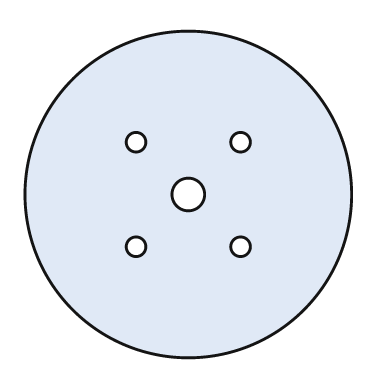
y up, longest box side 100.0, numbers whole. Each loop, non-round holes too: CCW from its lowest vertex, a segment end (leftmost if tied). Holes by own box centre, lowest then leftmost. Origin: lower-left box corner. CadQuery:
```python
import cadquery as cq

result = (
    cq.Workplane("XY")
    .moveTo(50.0, 50.0)
    .circle(50.0)
    .moveTo(34.0, 34.0)
    .circle(3.0)
    .moveTo(66.0, 34.0)
    .circle(3.0)
    .moveTo(50.0, 50.0)
    .circle(5.0)
    .moveTo(34.0, 66.0)
    .circle(3.0)
    .moveTo(66.0, 66.0)
    .circle(3.0)
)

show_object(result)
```